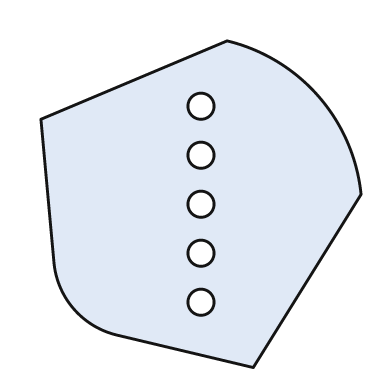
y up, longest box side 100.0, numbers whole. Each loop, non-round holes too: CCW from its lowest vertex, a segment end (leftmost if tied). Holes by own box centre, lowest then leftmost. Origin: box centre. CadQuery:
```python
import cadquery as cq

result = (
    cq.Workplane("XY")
    .moveTo(16.0, -50.0)
    .lineTo(49.0, 3.0)
    .threePointArc((36.0, 33.0), (8.0, 50.0))
    .lineTo(-49.0, 26.0)
    .lineTo(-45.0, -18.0)
    .threePointArc((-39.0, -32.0), (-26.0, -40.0))
    .close()
    .moveTo(0.0, -30.0)
    .circle(4.0)
    .moveTo(0.0, -15.0)
    .circle(4.0)
    .moveTo(0.0, 0.0)
    .circle(4.0)
    .moveTo(0.0, 15.0)
    .circle(4.0)
    .moveTo(0.0, 30.0)
    .circle(4.0)
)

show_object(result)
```